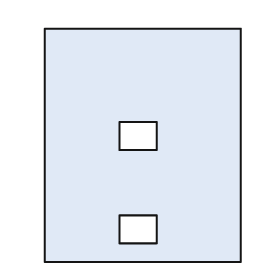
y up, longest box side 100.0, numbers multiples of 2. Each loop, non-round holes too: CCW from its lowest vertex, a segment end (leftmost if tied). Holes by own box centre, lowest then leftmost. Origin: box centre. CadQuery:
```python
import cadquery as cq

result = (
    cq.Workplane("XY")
    .moveTo(-42.0, -50.0)
    .lineTo(42.0, -50.0)
    .lineTo(42.0, 50.0)
    .lineTo(-42.0, 50.0)
    .close()
    .moveTo(-10.0, -42.0)
    .lineTo(6.0, -42.0)
    .lineTo(6.0, -30.0)
    .lineTo(-10.0, -30.0)
    .close()
    .moveTo(-10.0, -2.0)
    .lineTo(6.0, -2.0)
    .lineTo(6.0, 10.0)
    .lineTo(-10.0, 10.0)
    .close()
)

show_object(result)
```